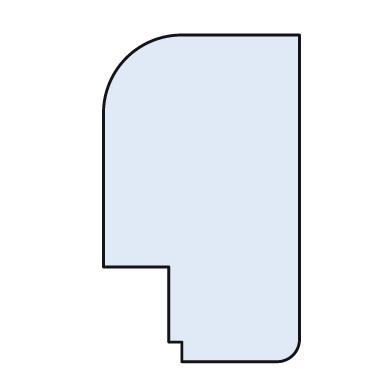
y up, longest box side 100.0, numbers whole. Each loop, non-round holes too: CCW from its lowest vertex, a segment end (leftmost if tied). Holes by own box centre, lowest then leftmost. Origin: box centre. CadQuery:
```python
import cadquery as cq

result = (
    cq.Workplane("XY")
    .moveTo(-6.0, -50.0)
    .lineTo(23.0, -50.0)
    .threePointArc((28.0, -48.0), (30.0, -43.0))
    .lineTo(30.0, 50.0)
    .lineTo(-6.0, 50.0)
    .threePointArc((-23.0, 43.0), (-30.0, 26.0))
    .lineTo(-30.0, -21.0)
    .lineTo(-10.0, -21.0)
    .lineTo(-10.0, -44.0)
    .lineTo(-6.0, -44.0)
    .close()
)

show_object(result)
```